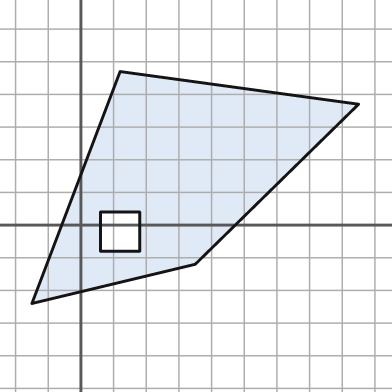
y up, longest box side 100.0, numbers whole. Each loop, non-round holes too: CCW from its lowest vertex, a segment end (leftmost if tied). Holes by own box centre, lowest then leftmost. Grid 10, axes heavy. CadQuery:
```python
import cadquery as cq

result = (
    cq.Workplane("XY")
    .moveTo(-15.0, -24.0)
    .lineTo(35.0, -12.0)
    .lineTo(85.0, 37.0)
    .lineTo(12.0, 47.0)
    .close()
    .moveTo(6.0, -8.0)
    .lineTo(18.0, -8.0)
    .lineTo(18.0, 4.0)
    .lineTo(6.0, 4.0)
    .close()
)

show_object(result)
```